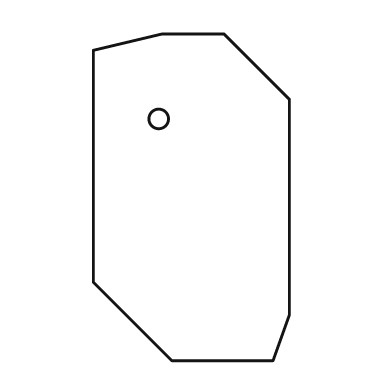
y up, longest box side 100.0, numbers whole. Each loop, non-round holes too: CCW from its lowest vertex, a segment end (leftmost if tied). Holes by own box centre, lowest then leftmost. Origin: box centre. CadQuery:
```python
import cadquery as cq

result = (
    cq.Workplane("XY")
    .moveTo(-6.0, -50.0)
    .lineTo(25.0, -50.0)
    .lineTo(30.0, -36.0)
    .lineTo(30.0, 30.0)
    .lineTo(10.0, 50.0)
    .lineTo(-9.0, 50.0)
    .lineTo(-30.0, 45.0)
    .lineTo(-30.0, -26.0)
    .close()
    .moveTo(-10.0, 24.0)
    .circle(3.0)
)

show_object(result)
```